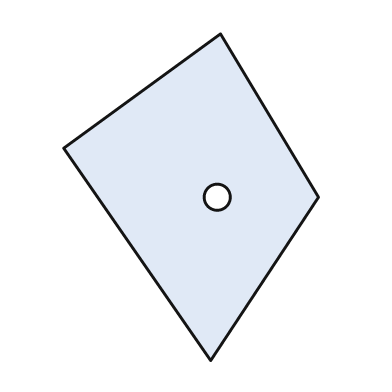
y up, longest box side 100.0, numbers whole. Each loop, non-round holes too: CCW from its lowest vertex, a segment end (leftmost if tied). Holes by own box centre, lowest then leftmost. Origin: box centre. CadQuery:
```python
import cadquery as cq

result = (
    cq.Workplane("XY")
    .moveTo(6.0, -50.0)
    .lineTo(39.0, 0.0)
    .lineTo(9.0, 50.0)
    .lineTo(-39.0, 15.0)
    .close()
    .moveTo(8.0, 0.0)
    .circle(4.0)
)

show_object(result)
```